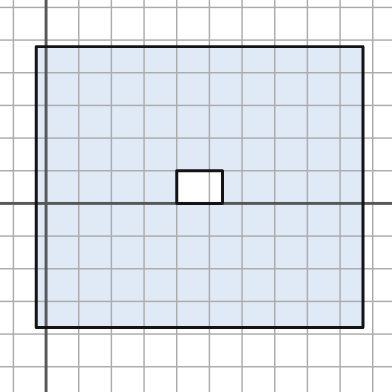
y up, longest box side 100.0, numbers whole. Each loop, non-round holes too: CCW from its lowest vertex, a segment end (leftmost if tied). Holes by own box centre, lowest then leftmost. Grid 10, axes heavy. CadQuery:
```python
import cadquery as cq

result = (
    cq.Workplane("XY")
    .moveTo(-3.0, -38.0)
    .lineTo(97.0, -38.0)
    .lineTo(97.0, 48.0)
    .lineTo(-3.0, 48.0)
    .close()
    .moveTo(40.0, 0.0)
    .lineTo(54.0, 0.0)
    .lineTo(54.0, 10.0)
    .lineTo(40.0, 10.0)
    .close()
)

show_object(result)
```